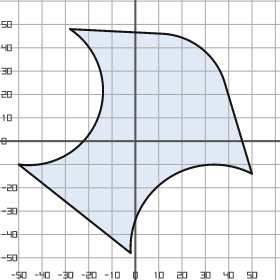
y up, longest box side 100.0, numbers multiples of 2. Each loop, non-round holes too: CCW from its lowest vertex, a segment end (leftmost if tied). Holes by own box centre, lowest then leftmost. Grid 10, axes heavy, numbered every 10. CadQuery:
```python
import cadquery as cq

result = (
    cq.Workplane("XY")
    .moveTo(-2.0, -48.0)
    .threePointArc((14.0, -16.0), (50.0, -14.0))
    .lineTo(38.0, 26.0)
    .threePointArc((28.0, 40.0), (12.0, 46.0))
    .lineTo(-28.0, 48.0)
    .threePointArc((-16.0, 10.0), (-50.0, -10.0))
    .close()
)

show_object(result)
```